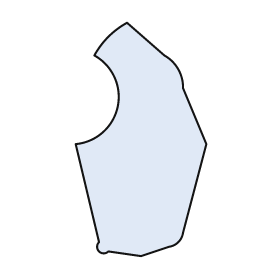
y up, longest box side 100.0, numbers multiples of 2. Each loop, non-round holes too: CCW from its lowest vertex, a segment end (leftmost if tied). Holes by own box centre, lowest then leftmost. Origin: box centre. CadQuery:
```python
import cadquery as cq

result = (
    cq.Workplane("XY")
    .moveTo(0.0, -50.0)
    .lineTo(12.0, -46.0)
    .threePointArc((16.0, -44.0), (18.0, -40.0))
    .lineTo(28.0, -2.0)
    .lineTo(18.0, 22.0)
    .threePointArc((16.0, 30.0), (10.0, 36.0))
    .lineTo(-6.0, 50.0)
    .threePointArc((-14.0, 44.0), (-20.0, 36.0))
    .threePointArc((-10.0, 14.0), (-28.0, -2.0))
    .lineTo(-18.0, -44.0)
    .threePointArc((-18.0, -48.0), (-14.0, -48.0))
    .close()
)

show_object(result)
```